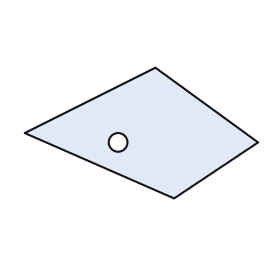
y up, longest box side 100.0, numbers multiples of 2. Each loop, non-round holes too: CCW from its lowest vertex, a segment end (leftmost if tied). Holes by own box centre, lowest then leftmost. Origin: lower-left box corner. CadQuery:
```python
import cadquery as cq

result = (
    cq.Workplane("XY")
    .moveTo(64.0, 0.0)
    .lineTo(100.0, 24.0)
    .lineTo(56.0, 56.0)
    .lineTo(0.0, 28.0)
    .close()
    .moveTo(40.0, 24.0)
    .circle(4.0)
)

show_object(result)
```